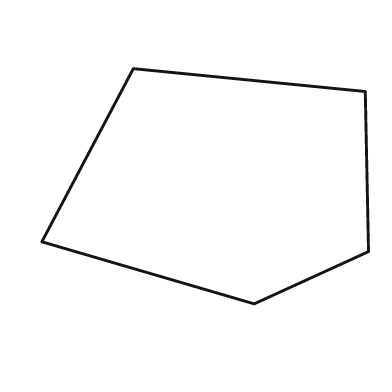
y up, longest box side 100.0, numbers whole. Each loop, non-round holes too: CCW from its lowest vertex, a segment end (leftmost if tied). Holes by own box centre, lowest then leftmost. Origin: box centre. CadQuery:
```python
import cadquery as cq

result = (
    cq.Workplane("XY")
    .moveTo(15.0, -36.0)
    .lineTo(50.0, -20.0)
    .lineTo(49.0, 29.0)
    .lineTo(-22.0, 36.0)
    .lineTo(-50.0, -17.0)
    .close()
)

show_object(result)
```